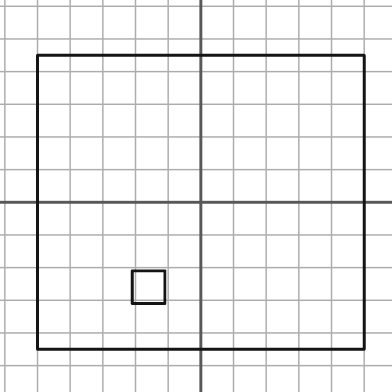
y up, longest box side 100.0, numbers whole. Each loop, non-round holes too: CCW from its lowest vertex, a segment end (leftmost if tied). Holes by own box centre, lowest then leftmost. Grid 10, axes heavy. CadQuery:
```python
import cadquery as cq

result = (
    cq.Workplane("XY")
    .moveTo(-50.0, -45.0)
    .lineTo(50.0, -45.0)
    .lineTo(50.0, 45.0)
    .lineTo(-50.0, 45.0)
    .close()
    .moveTo(-21.0, -31.0)
    .lineTo(-11.0, -31.0)
    .lineTo(-11.0, -21.0)
    .lineTo(-21.0, -21.0)
    .close()
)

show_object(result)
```